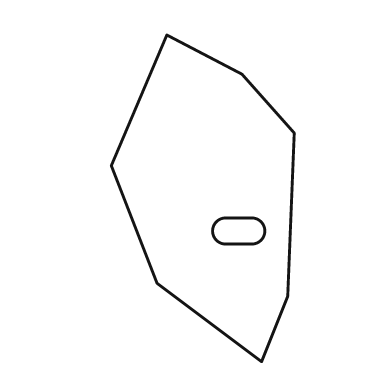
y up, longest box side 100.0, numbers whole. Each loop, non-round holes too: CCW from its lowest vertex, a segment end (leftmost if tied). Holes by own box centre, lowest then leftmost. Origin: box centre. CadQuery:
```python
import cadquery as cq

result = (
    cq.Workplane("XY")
    .moveTo(18.0, -50.0)
    .lineTo(26.0, -30.0)
    .lineTo(28.0, 20.0)
    .lineTo(12.0, 38.0)
    .lineTo(-11.0, 50.0)
    .lineTo(-28.0, 10.0)
    .lineTo(-14.0, -26.0)
    .close()
    .moveTo(7.0, -14.0)
    .lineTo(15.0, -14.0)
    .threePointArc((19.0, -10.0), (15.0, -6.0))
    .lineTo(7.0, -6.0)
    .threePointArc((3.0, -10.0), (7.0, -14.0))
    .close()
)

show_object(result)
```